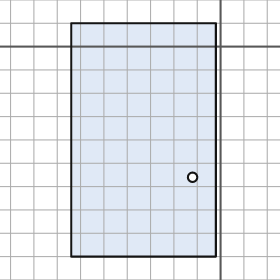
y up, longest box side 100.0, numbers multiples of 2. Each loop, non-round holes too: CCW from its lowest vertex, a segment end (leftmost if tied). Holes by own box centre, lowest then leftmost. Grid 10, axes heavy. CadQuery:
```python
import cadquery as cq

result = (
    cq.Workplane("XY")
    .moveTo(-64.0, -90.0)
    .lineTo(-2.0, -90.0)
    .lineTo(-2.0, 10.0)
    .lineTo(-64.0, 10.0)
    .close()
    .moveTo(-12.0, -56.0)
    .circle(2.0)
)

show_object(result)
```